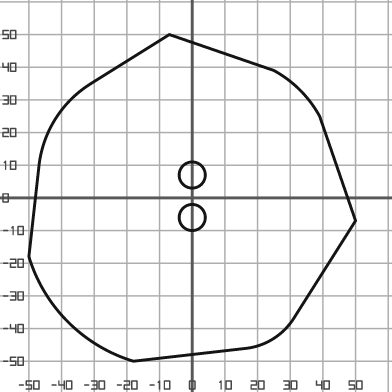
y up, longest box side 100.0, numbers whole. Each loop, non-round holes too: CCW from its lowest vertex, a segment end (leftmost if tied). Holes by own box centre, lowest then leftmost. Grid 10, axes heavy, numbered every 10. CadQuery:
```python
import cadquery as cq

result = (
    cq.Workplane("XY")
    .moveTo(-18.0, -50.0)
    .lineTo(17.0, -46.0)
    .threePointArc((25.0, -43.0), (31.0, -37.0))
    .lineTo(50.0, -7.0)
    .lineTo(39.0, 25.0)
    .threePointArc((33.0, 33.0), (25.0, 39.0))
    .lineTo(-7.0, 50.0)
    .lineTo(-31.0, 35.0)
    .threePointArc((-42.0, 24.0), (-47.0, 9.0))
    .lineTo(-50.0, -18.0)
    .threePointArc((-38.0, -38.0), (-18.0, -50.0))
    .close()
    .moveTo(0.0, -6.0)
    .circle(4.0)
    .moveTo(0.0, 7.0)
    .circle(4.0)
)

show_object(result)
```